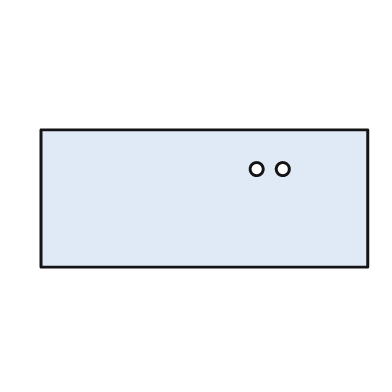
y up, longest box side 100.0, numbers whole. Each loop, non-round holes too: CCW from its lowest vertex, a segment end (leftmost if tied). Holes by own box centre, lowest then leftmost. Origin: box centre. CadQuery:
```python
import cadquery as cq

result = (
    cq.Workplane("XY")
    .moveTo(-50.0, -21.0)
    .lineTo(50.0, -21.0)
    .lineTo(50.0, 21.0)
    .lineTo(-50.0, 21.0)
    .close()
    .moveTo(16.0, 9.0)
    .circle(2.0)
    .moveTo(24.0, 9.0)
    .circle(2.0)
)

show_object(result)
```